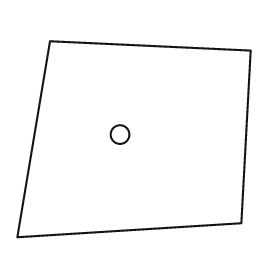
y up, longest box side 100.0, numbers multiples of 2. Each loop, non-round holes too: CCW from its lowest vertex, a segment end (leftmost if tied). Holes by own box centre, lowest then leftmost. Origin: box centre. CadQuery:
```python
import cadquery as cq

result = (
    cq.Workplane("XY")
    .moveTo(-50.0, -42.0)
    .lineTo(46.0, -36.0)
    .lineTo(50.0, 38.0)
    .lineTo(-36.0, 42.0)
    .close()
    .moveTo(-6.0, 2.0)
    .circle(4.0)
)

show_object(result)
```